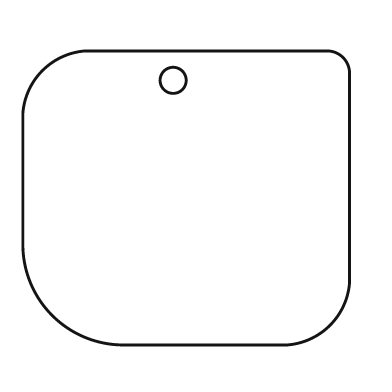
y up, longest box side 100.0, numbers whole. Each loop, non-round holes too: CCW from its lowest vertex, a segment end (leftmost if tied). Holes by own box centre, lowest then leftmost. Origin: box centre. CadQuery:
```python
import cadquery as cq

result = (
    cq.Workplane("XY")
    .moveTo(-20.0, -45.0)
    .lineTo(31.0, -45.0)
    .threePointArc((44.0, -39.0), (50.0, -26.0))
    .lineTo(50.0, 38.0)
    .threePointArc((48.0, 43.0), (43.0, 45.0))
    .lineTo(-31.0, 45.0)
    .threePointArc((-44.0, 39.0), (-50.0, 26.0))
    .lineTo(-50.0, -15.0)
    .threePointArc((-41.0, -36.0), (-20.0, -45.0))
    .close()
    .moveTo(-4.0, 36.0)
    .circle(4.0)
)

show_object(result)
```